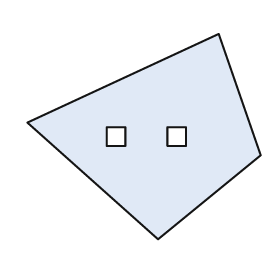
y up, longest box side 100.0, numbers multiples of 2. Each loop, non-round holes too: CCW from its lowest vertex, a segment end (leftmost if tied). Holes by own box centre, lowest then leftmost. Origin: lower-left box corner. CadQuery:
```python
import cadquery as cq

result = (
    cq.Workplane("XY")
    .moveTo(56.0, 0.0)
    .lineTo(100.0, 36.0)
    .lineTo(82.0, 88.0)
    .lineTo(0.0, 50.0)
    .close()
    .moveTo(34.0, 40.0)
    .lineTo(42.0, 40.0)
    .lineTo(42.0, 48.0)
    .lineTo(34.0, 48.0)
    .close()
    .moveTo(60.0, 40.0)
    .lineTo(68.0, 40.0)
    .lineTo(68.0, 48.0)
    .lineTo(60.0, 48.0)
    .close()
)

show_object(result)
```